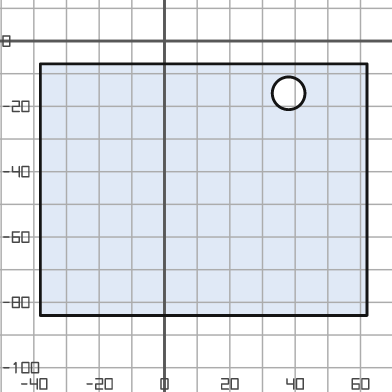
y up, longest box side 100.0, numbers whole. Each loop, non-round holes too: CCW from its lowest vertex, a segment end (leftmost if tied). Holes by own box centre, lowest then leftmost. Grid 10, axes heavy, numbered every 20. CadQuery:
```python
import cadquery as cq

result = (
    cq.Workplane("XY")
    .moveTo(-38.0, -84.0)
    .lineTo(62.0, -84.0)
    .lineTo(62.0, -7.0)
    .lineTo(-38.0, -7.0)
    .close()
    .moveTo(38.0, -16.0)
    .circle(5.0)
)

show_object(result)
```